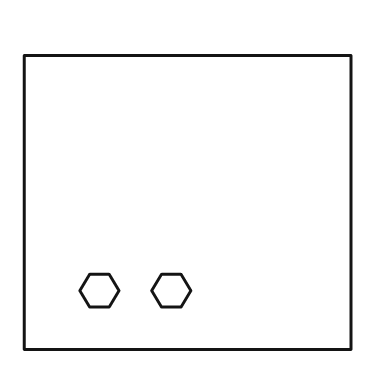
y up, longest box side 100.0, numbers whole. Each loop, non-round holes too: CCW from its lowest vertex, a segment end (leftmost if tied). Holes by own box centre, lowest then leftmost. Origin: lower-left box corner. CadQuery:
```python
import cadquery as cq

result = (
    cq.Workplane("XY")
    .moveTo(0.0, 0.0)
    .lineTo(100.0, 0.0)
    .lineTo(100.0, 90.0)
    .lineTo(0.0, 90.0)
    .close()
    .moveTo(20.0, 13.0)
    .lineTo(26.0, 13.0)
    .lineTo(29.0, 18.0)
    .lineTo(26.0, 23.0)
    .lineTo(20.0, 23.0)
    .lineTo(17.0, 18.0)
    .close()
    .moveTo(42.0, 13.0)
    .lineTo(48.0, 13.0)
    .lineTo(51.0, 18.0)
    .lineTo(48.0, 23.0)
    .lineTo(42.0, 23.0)
    .lineTo(39.0, 18.0)
    .close()
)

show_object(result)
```